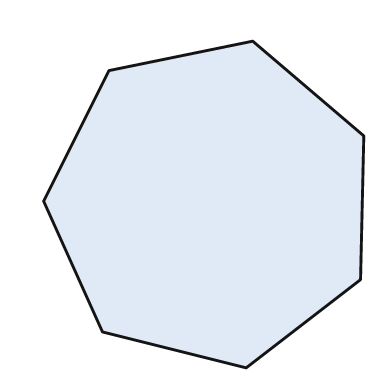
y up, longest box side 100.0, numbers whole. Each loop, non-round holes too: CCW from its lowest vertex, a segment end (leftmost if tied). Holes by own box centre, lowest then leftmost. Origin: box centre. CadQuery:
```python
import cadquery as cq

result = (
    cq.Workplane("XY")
    .moveTo(13.0, -50.0)
    .lineTo(48.0, -23.0)
    .lineTo(49.0, 21.0)
    .lineTo(15.0, 50.0)
    .lineTo(-29.0, 41.0)
    .lineTo(-49.0, 1.0)
    .lineTo(-31.0, -39.0)
    .close()
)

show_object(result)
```